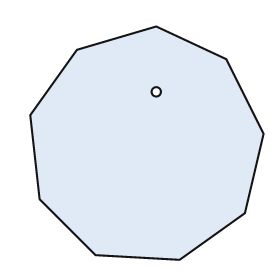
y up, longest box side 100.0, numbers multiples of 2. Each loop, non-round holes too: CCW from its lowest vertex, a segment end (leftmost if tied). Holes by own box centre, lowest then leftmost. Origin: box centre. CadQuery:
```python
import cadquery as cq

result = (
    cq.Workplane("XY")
    .moveTo(14.0, -50.0)
    .lineTo(42.0, -30.0)
    .lineTo(50.0, 4.0)
    .lineTo(34.0, 36.0)
    .lineTo(4.0, 50.0)
    .lineTo(-30.0, 40.0)
    .lineTo(-50.0, 12.0)
    .lineTo(-46.0, -24.0)
    .lineTo(-22.0, -48.0)
    .close()
    .moveTo(4.0, 22.0)
    .circle(2.0)
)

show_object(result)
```